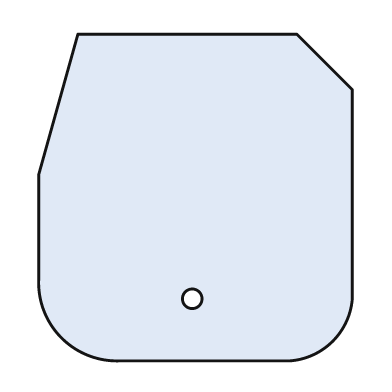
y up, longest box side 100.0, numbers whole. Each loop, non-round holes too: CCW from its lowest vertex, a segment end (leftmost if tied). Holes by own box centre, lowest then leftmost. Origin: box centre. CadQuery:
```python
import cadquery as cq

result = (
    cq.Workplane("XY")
    .moveTo(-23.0, -50.0)
    .lineTo(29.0, -50.0)
    .threePointArc((42.0, -44.0), (48.0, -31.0))
    .lineTo(48.0, 33.0)
    .lineTo(31.0, 50.0)
    .lineTo(-36.0, 50.0)
    .lineTo(-48.0, 7.0)
    .lineTo(-48.0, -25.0)
    .threePointArc((-41.0, -43.0), (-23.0, -50.0))
    .close()
    .moveTo(-1.0, -31.0)
    .circle(3.0)
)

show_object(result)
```